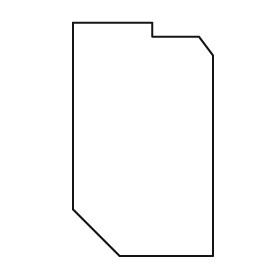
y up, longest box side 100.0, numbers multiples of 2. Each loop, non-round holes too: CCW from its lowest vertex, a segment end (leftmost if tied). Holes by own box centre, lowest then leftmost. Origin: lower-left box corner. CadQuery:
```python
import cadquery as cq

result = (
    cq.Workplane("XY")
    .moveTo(20.0, 0.0)
    .lineTo(60.0, 0.0)
    .lineTo(60.0, 86.0)
    .lineTo(54.0, 94.0)
    .lineTo(34.0, 94.0)
    .lineTo(34.0, 100.0)
    .lineTo(0.0, 100.0)
    .lineTo(0.0, 20.0)
    .close()
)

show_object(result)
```